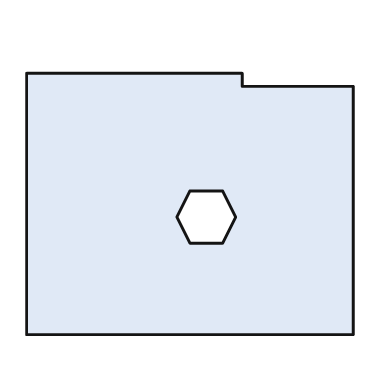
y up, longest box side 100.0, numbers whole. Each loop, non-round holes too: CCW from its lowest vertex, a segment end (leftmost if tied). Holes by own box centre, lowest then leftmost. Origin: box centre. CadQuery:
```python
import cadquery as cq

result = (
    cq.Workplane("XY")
    .moveTo(-50.0, -40.0)
    .lineTo(50.0, -40.0)
    .lineTo(50.0, 36.0)
    .lineTo(16.0, 36.0)
    .lineTo(16.0, 40.0)
    .lineTo(-50.0, 40.0)
    .close()
    .moveTo(0.0, -12.0)
    .lineTo(10.0, -12.0)
    .lineTo(14.0, -4.0)
    .lineTo(10.0, 4.0)
    .lineTo(0.0, 4.0)
    .lineTo(-4.0, -4.0)
    .close()
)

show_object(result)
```